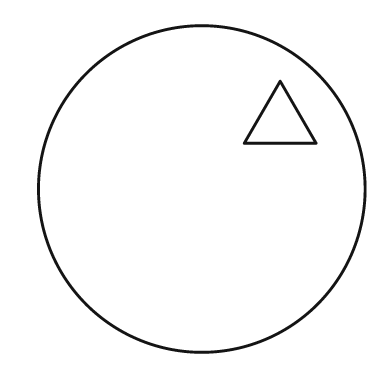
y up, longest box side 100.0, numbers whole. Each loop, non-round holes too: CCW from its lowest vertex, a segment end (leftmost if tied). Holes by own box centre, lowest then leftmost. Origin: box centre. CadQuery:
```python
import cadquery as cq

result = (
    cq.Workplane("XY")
    .moveTo(0.0, 0.0)
    .circle(50.0)
    .moveTo(13.0, 14.0)
    .lineTo(35.0, 14.0)
    .lineTo(24.0, 33.0)
    .close()
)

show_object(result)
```